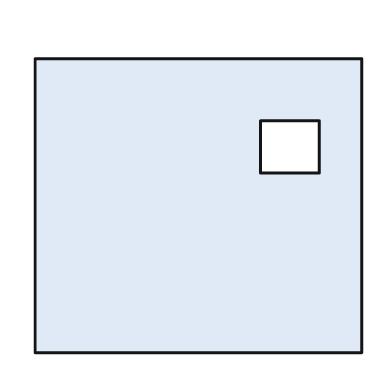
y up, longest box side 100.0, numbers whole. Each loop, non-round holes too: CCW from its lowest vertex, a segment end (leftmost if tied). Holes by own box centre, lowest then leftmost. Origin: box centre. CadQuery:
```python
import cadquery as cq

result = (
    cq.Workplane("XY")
    .moveTo(-50.0, -45.0)
    .lineTo(50.0, -45.0)
    .lineTo(50.0, 45.0)
    .lineTo(-50.0, 45.0)
    .close()
    .moveTo(19.0, 10.0)
    .lineTo(37.0, 10.0)
    .lineTo(37.0, 26.0)
    .lineTo(19.0, 26.0)
    .close()
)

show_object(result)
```